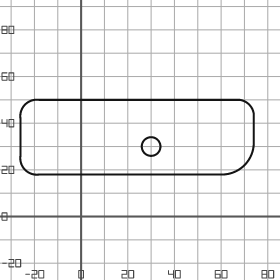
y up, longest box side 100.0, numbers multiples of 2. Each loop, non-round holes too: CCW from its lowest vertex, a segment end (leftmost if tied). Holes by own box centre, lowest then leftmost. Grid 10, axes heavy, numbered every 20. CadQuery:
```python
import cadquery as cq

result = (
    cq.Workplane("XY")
    .moveTo(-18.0, 18.0)
    .lineTo(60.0, 18.0)
    .threePointArc((70.0, 22.0), (74.0, 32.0))
    .lineTo(74.0, 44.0)
    .threePointArc((72.0, 48.0), (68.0, 50.0))
    .lineTo(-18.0, 50.0)
    .threePointArc((-24.0, 48.0), (-26.0, 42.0))
    .lineTo(-26.0, 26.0)
    .threePointArc((-24.0, 20.0), (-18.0, 18.0))
    .close()
    .moveTo(30.0, 30.0)
    .circle(4.0)
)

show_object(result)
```